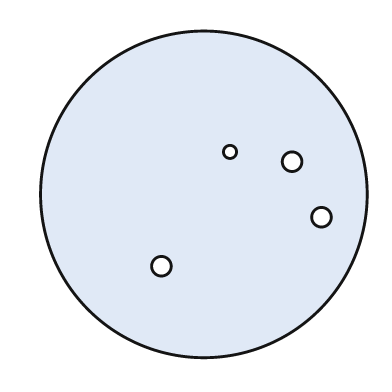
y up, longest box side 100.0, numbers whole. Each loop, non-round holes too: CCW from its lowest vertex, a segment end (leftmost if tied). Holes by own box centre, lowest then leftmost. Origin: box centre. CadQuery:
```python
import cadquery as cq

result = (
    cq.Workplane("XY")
    .moveTo(0.0, 0.0)
    .circle(50.0)
    .moveTo(-13.0, -22.0)
    .circle(3.0)
    .moveTo(36.0, -7.0)
    .circle(3.0)
    .moveTo(27.0, 10.0)
    .circle(3.0)
    .moveTo(8.0, 13.0)
    .circle(2.0)
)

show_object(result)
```